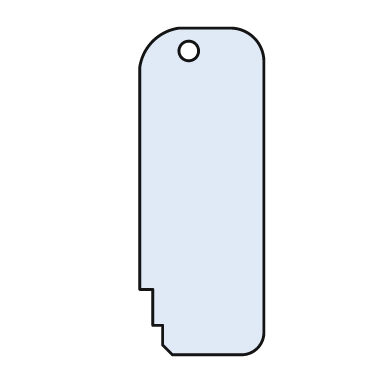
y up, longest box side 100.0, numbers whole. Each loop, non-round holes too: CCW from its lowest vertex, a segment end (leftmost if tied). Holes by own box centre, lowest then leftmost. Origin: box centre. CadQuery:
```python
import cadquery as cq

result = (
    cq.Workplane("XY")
    .moveTo(-9.0, -50.0)
    .lineTo(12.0, -50.0)
    .threePointArc((17.0, -48.0), (19.0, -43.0))
    .lineTo(19.0, 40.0)
    .threePointArc((16.0, 47.0), (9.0, 50.0))
    .lineTo(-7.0, 50.0)
    .threePointArc((-15.0, 46.0), (-19.0, 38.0))
    .lineTo(-19.0, -30.0)
    .lineTo(-15.0, -30.0)
    .lineTo(-15.0, -41.0)
    .lineTo(-12.0, -41.0)
    .lineTo(-12.0, -47.0)
    .close()
    .moveTo(-4.0, 43.0)
    .circle(3.0)
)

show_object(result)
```